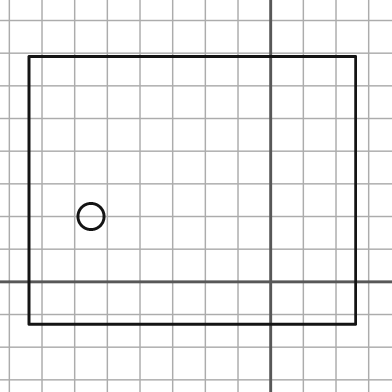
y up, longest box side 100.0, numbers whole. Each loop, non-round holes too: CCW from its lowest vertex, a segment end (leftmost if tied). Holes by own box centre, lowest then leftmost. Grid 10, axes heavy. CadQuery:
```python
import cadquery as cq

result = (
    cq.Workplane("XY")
    .moveTo(-74.0, -13.0)
    .lineTo(26.0, -13.0)
    .lineTo(26.0, 69.0)
    .lineTo(-74.0, 69.0)
    .close()
    .moveTo(-55.0, 20.0)
    .circle(4.0)
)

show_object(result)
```